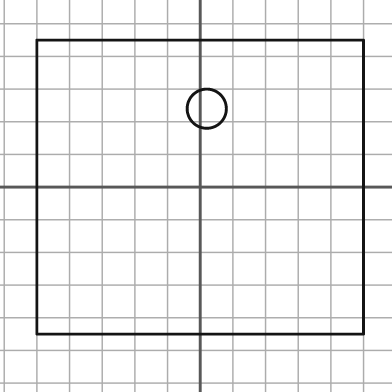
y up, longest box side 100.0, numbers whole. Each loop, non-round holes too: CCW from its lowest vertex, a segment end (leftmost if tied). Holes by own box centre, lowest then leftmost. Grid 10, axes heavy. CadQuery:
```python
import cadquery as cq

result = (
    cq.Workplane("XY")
    .moveTo(-50.0, -45.0)
    .lineTo(50.0, -45.0)
    .lineTo(50.0, 45.0)
    .lineTo(-50.0, 45.0)
    .close()
    .moveTo(2.0, 24.0)
    .circle(6.0)
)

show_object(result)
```